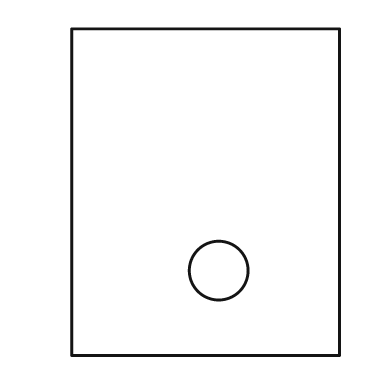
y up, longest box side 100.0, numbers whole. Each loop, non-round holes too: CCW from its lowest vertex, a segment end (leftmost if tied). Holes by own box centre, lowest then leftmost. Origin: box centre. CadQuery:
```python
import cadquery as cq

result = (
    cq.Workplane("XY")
    .moveTo(-41.0, -50.0)
    .lineTo(41.0, -50.0)
    .lineTo(41.0, 50.0)
    .lineTo(-41.0, 50.0)
    .close()
    .moveTo(4.0, -24.0)
    .circle(9.0)
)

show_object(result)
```